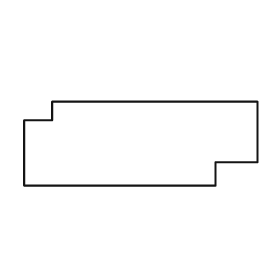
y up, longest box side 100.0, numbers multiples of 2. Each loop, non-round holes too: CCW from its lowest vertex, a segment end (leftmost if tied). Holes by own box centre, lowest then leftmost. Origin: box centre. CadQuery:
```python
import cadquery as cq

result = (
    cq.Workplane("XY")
    .moveTo(-50.0, -18.0)
    .lineTo(32.0, -18.0)
    .lineTo(32.0, -8.0)
    .lineTo(50.0, -8.0)
    .lineTo(50.0, 18.0)
    .lineTo(-38.0, 18.0)
    .lineTo(-38.0, 10.0)
    .lineTo(-50.0, 10.0)
    .close()
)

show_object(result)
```